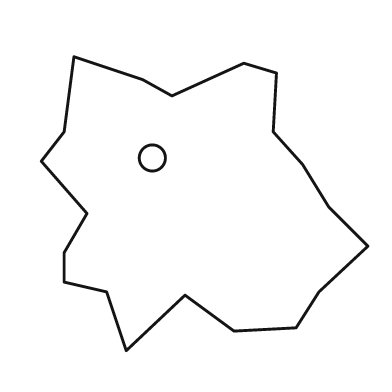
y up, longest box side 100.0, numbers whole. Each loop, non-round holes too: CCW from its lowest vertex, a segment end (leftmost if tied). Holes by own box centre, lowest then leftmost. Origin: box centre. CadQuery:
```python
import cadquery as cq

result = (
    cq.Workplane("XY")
    .moveTo(-24.0, -45.0)
    .lineTo(-6.0, -28.0)
    .lineTo(9.0, -39.0)
    .lineTo(28.0, -38.0)
    .lineTo(35.0, -27.0)
    .lineTo(50.0, -13.0)
    .lineTo(38.0, -1.0)
    .lineTo(30.0, 12.0)
    .lineTo(21.0, 22.0)
    .lineTo(22.0, 40.0)
    .lineTo(12.0, 43.0)
    .lineTo(-10.0, 33.0)
    .lineTo(-19.0, 38.0)
    .lineTo(-40.0, 45.0)
    .lineTo(-43.0, 22.0)
    .lineTo(-50.0, 13.0)
    .lineTo(-36.0, -3.0)
    .lineTo(-43.0, -15.0)
    .lineTo(-43.0, -24.0)
    .lineTo(-30.0, -27.0)
    .close()
    .moveTo(-16.0, 14.0)
    .circle(4.0)
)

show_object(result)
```